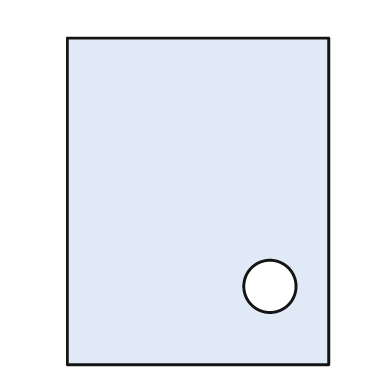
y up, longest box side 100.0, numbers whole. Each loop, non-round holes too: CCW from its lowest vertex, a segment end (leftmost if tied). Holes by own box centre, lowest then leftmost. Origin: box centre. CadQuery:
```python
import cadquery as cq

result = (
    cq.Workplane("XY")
    .moveTo(-40.0, -50.0)
    .lineTo(40.0, -50.0)
    .lineTo(40.0, 50.0)
    .lineTo(-40.0, 50.0)
    .close()
    .moveTo(22.0, -26.0)
    .circle(8.0)
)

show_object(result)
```